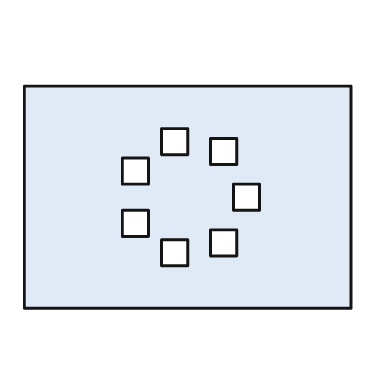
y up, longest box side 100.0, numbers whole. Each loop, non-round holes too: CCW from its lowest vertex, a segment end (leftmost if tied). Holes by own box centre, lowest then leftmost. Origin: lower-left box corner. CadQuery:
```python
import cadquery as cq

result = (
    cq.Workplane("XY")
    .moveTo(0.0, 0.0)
    .lineTo(100.0, 0.0)
    .lineTo(100.0, 68.0)
    .lineTo(0.0, 68.0)
    .close()
    .moveTo(42.0, 13.0)
    .lineTo(50.0, 13.0)
    .lineTo(50.0, 21.0)
    .lineTo(42.0, 21.0)
    .close()
    .moveTo(57.0, 16.0)
    .lineTo(65.0, 16.0)
    .lineTo(65.0, 24.0)
    .lineTo(57.0, 24.0)
    .close()
    .moveTo(30.0, 22.0)
    .lineTo(38.0, 22.0)
    .lineTo(38.0, 30.0)
    .lineTo(30.0, 30.0)
    .close()
    .moveTo(64.0, 30.0)
    .lineTo(72.0, 30.0)
    .lineTo(72.0, 38.0)
    .lineTo(64.0, 38.0)
    .close()
    .moveTo(30.0, 38.0)
    .lineTo(38.0, 38.0)
    .lineTo(38.0, 46.0)
    .lineTo(30.0, 46.0)
    .close()
    .moveTo(57.0, 44.0)
    .lineTo(65.0, 44.0)
    .lineTo(65.0, 52.0)
    .lineTo(57.0, 52.0)
    .close()
    .moveTo(42.0, 47.0)
    .lineTo(50.0, 47.0)
    .lineTo(50.0, 55.0)
    .lineTo(42.0, 55.0)
    .close()
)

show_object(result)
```